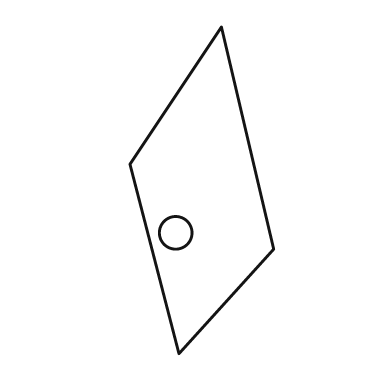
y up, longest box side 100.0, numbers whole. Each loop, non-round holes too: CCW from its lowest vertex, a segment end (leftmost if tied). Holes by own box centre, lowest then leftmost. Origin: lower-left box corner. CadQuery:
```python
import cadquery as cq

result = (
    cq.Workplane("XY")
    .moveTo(15.0, 0.0)
    .lineTo(44.0, 32.0)
    .lineTo(28.0, 100.0)
    .lineTo(0.0, 58.0)
    .close()
    .moveTo(14.0, 37.0)
    .circle(5.0)
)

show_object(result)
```